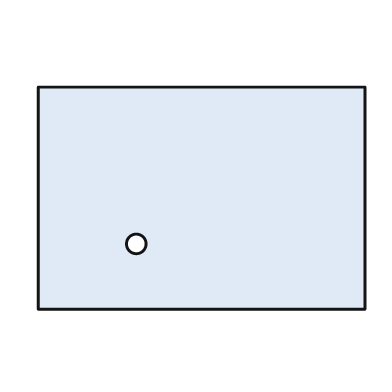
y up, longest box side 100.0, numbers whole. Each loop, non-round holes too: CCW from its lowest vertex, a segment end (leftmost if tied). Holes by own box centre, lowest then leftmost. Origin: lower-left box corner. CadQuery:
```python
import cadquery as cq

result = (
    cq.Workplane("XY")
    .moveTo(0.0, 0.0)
    .lineTo(100.0, 0.0)
    .lineTo(100.0, 68.0)
    .lineTo(0.0, 68.0)
    .close()
    .moveTo(30.0, 20.0)
    .circle(3.0)
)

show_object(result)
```